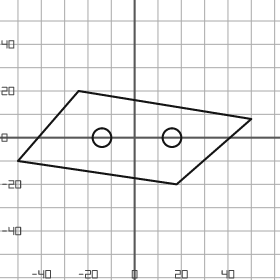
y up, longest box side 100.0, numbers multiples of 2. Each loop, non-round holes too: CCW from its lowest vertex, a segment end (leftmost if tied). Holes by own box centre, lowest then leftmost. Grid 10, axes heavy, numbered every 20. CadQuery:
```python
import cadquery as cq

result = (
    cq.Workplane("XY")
    .moveTo(18.0, -20.0)
    .lineTo(50.0, 8.0)
    .lineTo(-24.0, 20.0)
    .lineTo(-50.0, -10.0)
    .close()
    .moveTo(-14.0, 0.0)
    .circle(4.0)
    .moveTo(16.0, 0.0)
    .circle(4.0)
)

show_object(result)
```